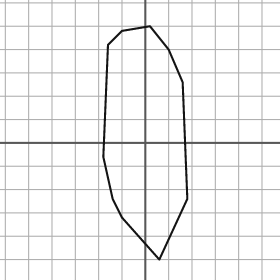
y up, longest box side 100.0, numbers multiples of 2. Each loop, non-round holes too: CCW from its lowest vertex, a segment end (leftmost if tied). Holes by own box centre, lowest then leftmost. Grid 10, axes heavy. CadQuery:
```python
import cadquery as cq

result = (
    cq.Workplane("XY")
    .moveTo(6.0, -50.0)
    .lineTo(18.0, -24.0)
    .lineTo(16.0, 26.0)
    .lineTo(10.0, 40.0)
    .lineTo(2.0, 50.0)
    .lineTo(-10.0, 48.0)
    .lineTo(-16.0, 42.0)
    .lineTo(-18.0, -6.0)
    .lineTo(-14.0, -24.0)
    .lineTo(-10.0, -32.0)
    .close()
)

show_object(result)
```